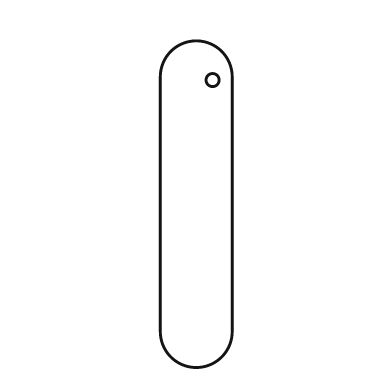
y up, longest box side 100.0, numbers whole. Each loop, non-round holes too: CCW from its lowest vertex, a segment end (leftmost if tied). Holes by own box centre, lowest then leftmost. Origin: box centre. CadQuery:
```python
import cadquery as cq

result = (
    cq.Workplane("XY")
    .moveTo(-11.0, -39.0)
    .threePointArc((0.0, -50.0), (11.0, -39.0))
    .lineTo(11.0, 39.0)
    .threePointArc((0.0, 50.0), (-11.0, 39.0))
    .close()
    .moveTo(5.0, 38.0)
    .circle(2.0)
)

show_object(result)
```